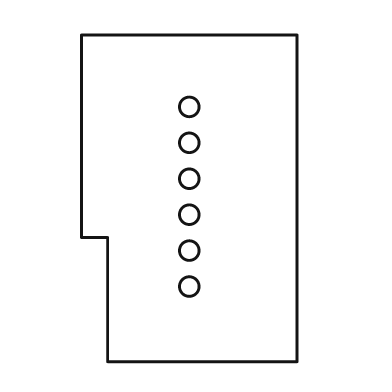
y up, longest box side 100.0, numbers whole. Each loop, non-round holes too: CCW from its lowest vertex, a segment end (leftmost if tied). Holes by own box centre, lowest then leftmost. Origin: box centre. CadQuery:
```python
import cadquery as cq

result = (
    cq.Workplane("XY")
    .moveTo(-25.0, -50.0)
    .lineTo(33.0, -50.0)
    .lineTo(33.0, 50.0)
    .lineTo(-33.0, 50.0)
    .lineTo(-33.0, -12.0)
    .lineTo(-25.0, -12.0)
    .close()
    .moveTo(0.0, -27.0)
    .circle(3.0)
    .moveTo(0.0, -16.0)
    .circle(3.0)
    .moveTo(0.0, -5.0)
    .circle(3.0)
    .moveTo(0.0, 6.0)
    .circle(3.0)
    .moveTo(0.0, 17.0)
    .circle(3.0)
    .moveTo(0.0, 28.0)
    .circle(3.0)
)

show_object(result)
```